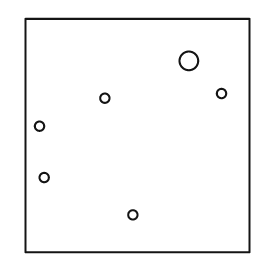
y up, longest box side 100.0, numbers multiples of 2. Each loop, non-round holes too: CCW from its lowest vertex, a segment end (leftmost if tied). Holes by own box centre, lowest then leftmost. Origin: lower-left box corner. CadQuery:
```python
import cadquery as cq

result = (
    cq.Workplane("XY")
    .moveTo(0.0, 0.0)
    .lineTo(96.0, 0.0)
    .lineTo(96.0, 100.0)
    .lineTo(0.0, 100.0)
    .close()
    .moveTo(46.0, 16.0)
    .circle(2.0)
    .moveTo(8.0, 32.0)
    .circle(2.0)
    .moveTo(6.0, 54.0)
    .circle(2.0)
    .moveTo(34.0, 66.0)
    .circle(2.0)
    .moveTo(84.0, 68.0)
    .circle(2.0)
    .moveTo(70.0, 82.0)
    .circle(4.0)
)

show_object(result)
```